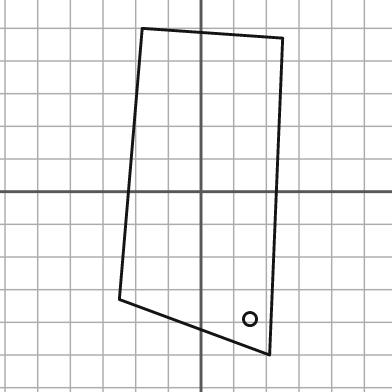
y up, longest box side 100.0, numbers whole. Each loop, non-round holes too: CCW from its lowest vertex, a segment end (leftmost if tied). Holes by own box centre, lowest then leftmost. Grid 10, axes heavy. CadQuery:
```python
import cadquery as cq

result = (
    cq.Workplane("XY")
    .moveTo(21.0, -50.0)
    .lineTo(25.0, 47.0)
    .lineTo(-18.0, 50.0)
    .lineTo(-25.0, -33.0)
    .close()
    .moveTo(15.0, -39.0)
    .circle(2.0)
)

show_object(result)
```